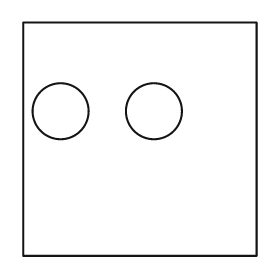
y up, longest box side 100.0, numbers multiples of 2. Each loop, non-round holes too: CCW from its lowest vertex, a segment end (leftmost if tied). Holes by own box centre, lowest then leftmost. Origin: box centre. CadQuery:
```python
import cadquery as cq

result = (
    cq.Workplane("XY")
    .moveTo(-50.0, -50.0)
    .lineTo(50.0, -50.0)
    .lineTo(50.0, 50.0)
    .lineTo(-50.0, 50.0)
    .close()
    .moveTo(-34.0, 12.0)
    .circle(12.0)
    .moveTo(6.0, 12.0)
    .circle(12.0)
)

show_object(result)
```